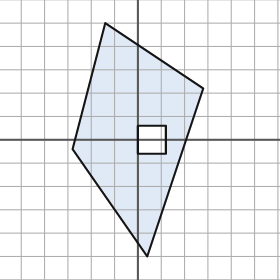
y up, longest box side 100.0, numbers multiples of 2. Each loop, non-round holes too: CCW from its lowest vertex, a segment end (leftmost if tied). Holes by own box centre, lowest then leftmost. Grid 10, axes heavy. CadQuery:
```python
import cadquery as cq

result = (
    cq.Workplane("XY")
    .moveTo(4.0, -50.0)
    .lineTo(28.0, 22.0)
    .lineTo(-14.0, 50.0)
    .lineTo(-28.0, -4.0)
    .close()
    .moveTo(0.0, -6.0)
    .lineTo(12.0, -6.0)
    .lineTo(12.0, 6.0)
    .lineTo(0.0, 6.0)
    .close()
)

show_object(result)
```